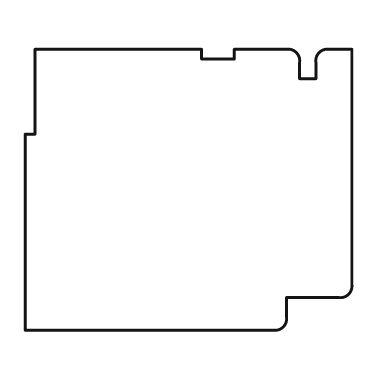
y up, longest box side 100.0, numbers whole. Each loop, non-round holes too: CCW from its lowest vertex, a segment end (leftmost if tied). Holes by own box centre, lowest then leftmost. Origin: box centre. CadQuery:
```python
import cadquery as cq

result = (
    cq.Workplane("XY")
    .moveTo(-50.0, -43.0)
    .lineTo(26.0, -43.0)
    .threePointArc((29.0, -42.0), (30.0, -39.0))
    .lineTo(30.0, -33.0)
    .lineTo(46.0, -33.0)
    .threePointArc((49.0, -32.0), (50.0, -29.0))
    .lineTo(50.0, 43.0)
    .lineTo(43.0, 43.0)
    .threePointArc((40.0, 42.0), (39.0, 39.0))
    .lineTo(39.0, 34.0)
    .lineTo(34.0, 34.0)
    .lineTo(34.0, 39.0)
    .threePointArc((33.0, 42.0), (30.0, 43.0))
    .lineTo(14.0, 43.0)
    .lineTo(14.0, 40.0)
    .lineTo(4.0, 40.0)
    .lineTo(4.0, 43.0)
    .lineTo(-47.0, 43.0)
    .lineTo(-47.0, 17.0)
    .lineTo(-50.0, 17.0)
    .close()
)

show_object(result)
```